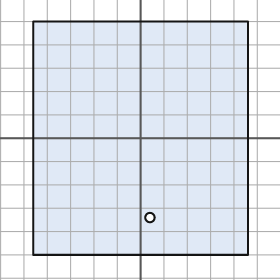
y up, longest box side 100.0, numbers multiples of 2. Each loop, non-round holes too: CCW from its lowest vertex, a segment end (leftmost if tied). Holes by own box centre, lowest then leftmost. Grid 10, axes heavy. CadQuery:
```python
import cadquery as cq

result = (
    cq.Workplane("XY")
    .moveTo(-46.0, -50.0)
    .lineTo(46.0, -50.0)
    .lineTo(46.0, 50.0)
    .lineTo(-46.0, 50.0)
    .close()
    .moveTo(4.0, -34.0)
    .circle(2.0)
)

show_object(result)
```